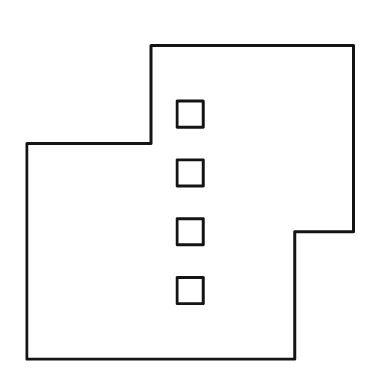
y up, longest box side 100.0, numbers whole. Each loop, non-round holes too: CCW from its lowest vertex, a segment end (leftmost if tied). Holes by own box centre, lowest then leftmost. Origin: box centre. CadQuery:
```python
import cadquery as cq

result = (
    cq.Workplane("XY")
    .moveTo(-50.0, -48.0)
    .lineTo(32.0, -48.0)
    .lineTo(32.0, -9.0)
    .lineTo(50.0, -9.0)
    .lineTo(50.0, 48.0)
    .lineTo(-12.0, 48.0)
    .lineTo(-12.0, 18.0)
    .lineTo(-50.0, 18.0)
    .close()
    .moveTo(-4.0, -31.0)
    .lineTo(4.0, -31.0)
    .lineTo(4.0, -23.0)
    .lineTo(-4.0, -23.0)
    .close()
    .moveTo(-4.0, -13.0)
    .lineTo(4.0, -13.0)
    .lineTo(4.0, -5.0)
    .lineTo(-4.0, -5.0)
    .close()
    .moveTo(-4.0, 5.0)
    .lineTo(4.0, 5.0)
    .lineTo(4.0, 13.0)
    .lineTo(-4.0, 13.0)
    .close()
    .moveTo(-4.0, 23.0)
    .lineTo(4.0, 23.0)
    .lineTo(4.0, 31.0)
    .lineTo(-4.0, 31.0)
    .close()
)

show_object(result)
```